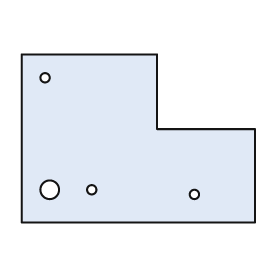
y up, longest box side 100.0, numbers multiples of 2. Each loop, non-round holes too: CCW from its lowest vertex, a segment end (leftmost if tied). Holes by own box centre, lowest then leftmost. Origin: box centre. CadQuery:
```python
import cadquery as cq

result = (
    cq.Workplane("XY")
    .moveTo(-50.0, -36.0)
    .lineTo(50.0, -36.0)
    .lineTo(50.0, 4.0)
    .lineTo(8.0, 4.0)
    .lineTo(8.0, 36.0)
    .lineTo(-50.0, 36.0)
    .close()
    .moveTo(24.0, -24.0)
    .circle(2.0)
    .moveTo(-38.0, -22.0)
    .circle(4.0)
    .moveTo(-20.0, -22.0)
    .circle(2.0)
    .moveTo(-40.0, 26.0)
    .circle(2.0)
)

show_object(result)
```